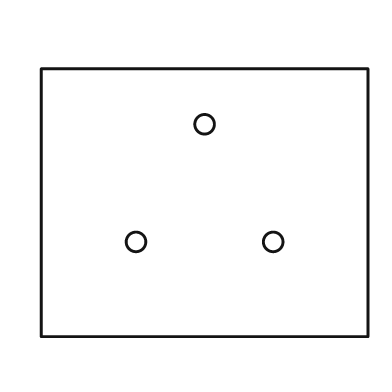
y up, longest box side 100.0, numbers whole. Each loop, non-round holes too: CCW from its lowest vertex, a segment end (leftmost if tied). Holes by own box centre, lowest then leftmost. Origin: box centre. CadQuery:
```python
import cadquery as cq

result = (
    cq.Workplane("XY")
    .moveTo(-50.0, -41.0)
    .lineTo(50.0, -41.0)
    .lineTo(50.0, 41.0)
    .lineTo(-50.0, 41.0)
    .close()
    .moveTo(-21.0, -12.0)
    .circle(3.0)
    .moveTo(21.0, -12.0)
    .circle(3.0)
    .moveTo(0.0, 24.0)
    .circle(3.0)
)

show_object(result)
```